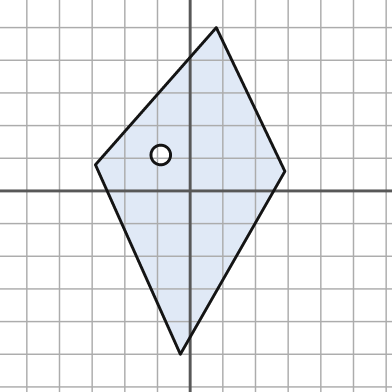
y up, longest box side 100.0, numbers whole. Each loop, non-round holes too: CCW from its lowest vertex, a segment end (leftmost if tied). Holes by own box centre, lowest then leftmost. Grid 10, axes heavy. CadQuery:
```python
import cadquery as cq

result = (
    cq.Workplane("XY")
    .moveTo(-3.0, -50.0)
    .lineTo(29.0, 6.0)
    .lineTo(8.0, 50.0)
    .lineTo(-29.0, 8.0)
    .close()
    .moveTo(-9.0, 11.0)
    .circle(3.0)
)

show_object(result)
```